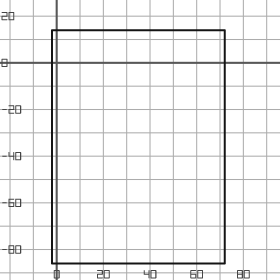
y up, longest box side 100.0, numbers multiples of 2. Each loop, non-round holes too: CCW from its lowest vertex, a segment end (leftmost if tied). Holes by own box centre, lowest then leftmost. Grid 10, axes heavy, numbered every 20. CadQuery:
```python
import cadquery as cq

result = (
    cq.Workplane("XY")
    .moveTo(-2.0, -86.0)
    .lineTo(72.0, -86.0)
    .lineTo(72.0, 14.0)
    .lineTo(-2.0, 14.0)
    .close()
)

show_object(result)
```